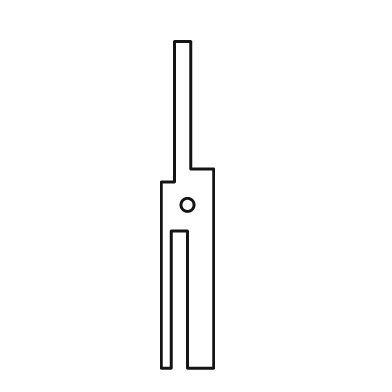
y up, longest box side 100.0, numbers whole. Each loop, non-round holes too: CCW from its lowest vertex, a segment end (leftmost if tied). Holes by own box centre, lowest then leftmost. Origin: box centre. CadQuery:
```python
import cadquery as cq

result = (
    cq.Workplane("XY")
    .moveTo(-8.0, -50.0)
    .lineTo(-5.0, -50.0)
    .lineTo(-5.0, -8.0)
    .lineTo(0.0, -8.0)
    .lineTo(0.0, -50.0)
    .lineTo(8.0, -50.0)
    .lineTo(8.0, 11.0)
    .lineTo(1.0, 11.0)
    .lineTo(1.0, 50.0)
    .lineTo(-4.0, 50.0)
    .lineTo(-4.0, 7.0)
    .lineTo(-8.0, 7.0)
    .close()
    .moveTo(0.0, 0.0)
    .circle(2.0)
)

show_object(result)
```